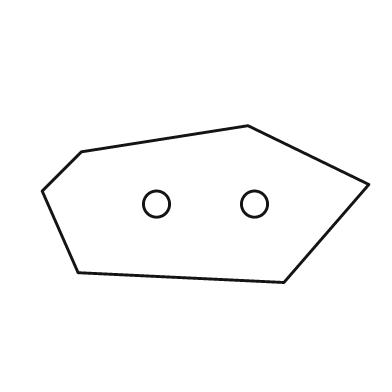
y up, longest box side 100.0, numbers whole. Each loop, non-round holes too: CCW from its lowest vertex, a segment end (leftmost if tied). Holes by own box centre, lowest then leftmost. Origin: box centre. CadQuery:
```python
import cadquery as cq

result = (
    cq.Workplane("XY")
    .moveTo(24.0, -24.0)
    .lineTo(50.0, 6.0)
    .lineTo(13.0, 24.0)
    .lineTo(-38.0, 16.0)
    .lineTo(-50.0, 4.0)
    .lineTo(-39.0, -21.0)
    .close()
    .moveTo(-15.0, 0.0)
    .circle(4.0)
    .moveTo(15.0, 0.0)
    .circle(4.0)
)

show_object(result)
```